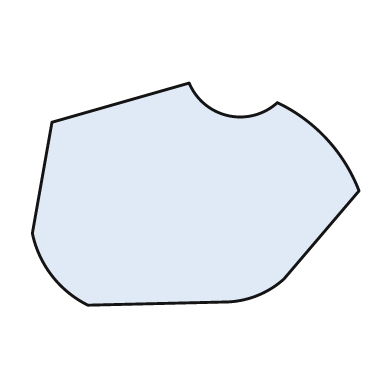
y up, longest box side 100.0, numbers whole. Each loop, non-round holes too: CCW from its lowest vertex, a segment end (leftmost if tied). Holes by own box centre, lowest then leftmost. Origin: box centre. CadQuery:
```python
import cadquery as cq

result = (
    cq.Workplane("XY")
    .moveTo(-33.0, -34.0)
    .lineTo(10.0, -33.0)
    .threePointArc((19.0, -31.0), (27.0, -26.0))
    .lineTo(50.0, 1.0)
    .threePointArc((40.0, 17.0), (25.0, 28.0))
    .threePointArc((10.0, 24.0), (-2.0, 34.0))
    .lineTo(-44.0, 22.0)
    .lineTo(-50.0, -12.0)
    .threePointArc((-44.0, -25.0), (-33.0, -34.0))
    .close()
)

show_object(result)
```